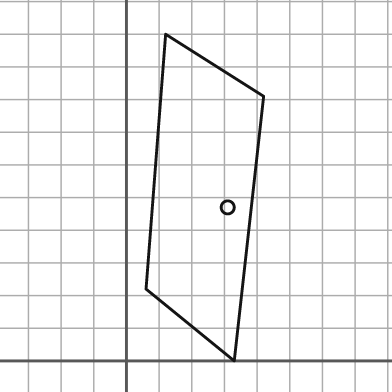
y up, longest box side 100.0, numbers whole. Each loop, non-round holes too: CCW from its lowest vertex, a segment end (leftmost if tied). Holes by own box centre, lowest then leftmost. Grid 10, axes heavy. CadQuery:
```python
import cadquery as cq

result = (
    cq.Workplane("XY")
    .moveTo(33.0, 0.0)
    .lineTo(42.0, 81.0)
    .lineTo(12.0, 100.0)
    .lineTo(6.0, 22.0)
    .close()
    .moveTo(31.0, 47.0)
    .circle(2.0)
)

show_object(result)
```